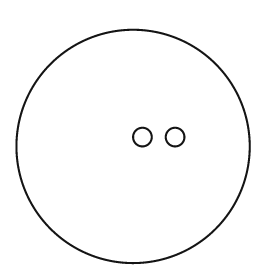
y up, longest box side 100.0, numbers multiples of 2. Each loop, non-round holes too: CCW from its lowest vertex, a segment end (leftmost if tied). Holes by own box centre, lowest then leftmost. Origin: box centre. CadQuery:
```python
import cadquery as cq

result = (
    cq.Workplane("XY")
    .moveTo(0.0, 0.0)
    .circle(50.0)
    .moveTo(4.0, 4.0)
    .circle(4.0)
    .moveTo(18.0, 4.0)
    .circle(4.0)
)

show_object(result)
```